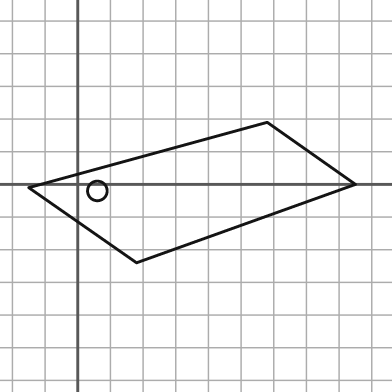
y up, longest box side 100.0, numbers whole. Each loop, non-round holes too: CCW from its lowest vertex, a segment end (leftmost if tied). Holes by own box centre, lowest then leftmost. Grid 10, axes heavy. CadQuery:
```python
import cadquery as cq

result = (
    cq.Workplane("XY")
    .moveTo(18.0, -24.0)
    .lineTo(85.0, 0.0)
    .lineTo(58.0, 19.0)
    .lineTo(-15.0, -1.0)
    .close()
    .moveTo(6.0, -2.0)
    .circle(3.0)
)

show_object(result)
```